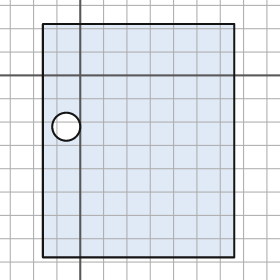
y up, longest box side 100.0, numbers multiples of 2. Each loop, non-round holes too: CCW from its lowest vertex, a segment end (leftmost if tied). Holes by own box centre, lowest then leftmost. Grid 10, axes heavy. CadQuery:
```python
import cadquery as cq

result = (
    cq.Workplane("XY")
    .moveTo(-16.0, -78.0)
    .lineTo(66.0, -78.0)
    .lineTo(66.0, 22.0)
    .lineTo(-16.0, 22.0)
    .close()
    .moveTo(-6.0, -22.0)
    .circle(6.0)
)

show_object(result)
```